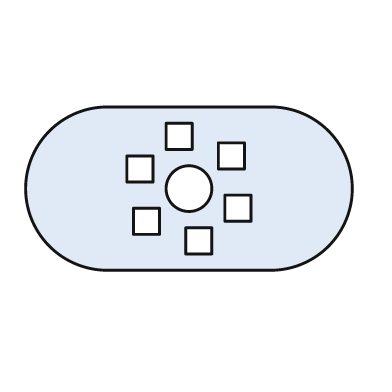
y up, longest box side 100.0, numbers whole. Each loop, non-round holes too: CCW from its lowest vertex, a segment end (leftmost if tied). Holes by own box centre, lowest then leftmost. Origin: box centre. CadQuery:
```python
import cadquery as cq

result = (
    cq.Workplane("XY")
    .moveTo(-25.0, -25.0)
    .lineTo(25.0, -25.0)
    .threePointArc((50.0, 0.0), (25.0, 25.0))
    .lineTo(-25.0, 25.0)
    .threePointArc((-50.0, 0.0), (-25.0, -25.0))
    .close()
    .moveTo(-1.0, -20.0)
    .lineTo(7.0, -20.0)
    .lineTo(7.0, -12.0)
    .lineTo(-1.0, -12.0)
    .close()
    .moveTo(-17.0, -14.0)
    .lineTo(-9.0, -14.0)
    .lineTo(-9.0, -6.0)
    .lineTo(-17.0, -6.0)
    .close()
    .moveTo(11.0, -10.0)
    .lineTo(19.0, -10.0)
    .lineTo(19.0, -2.0)
    .lineTo(11.0, -2.0)
    .close()
    .moveTo(0.0, 0.0)
    .circle(7.0)
    .moveTo(-19.0, 2.0)
    .lineTo(-11.0, 2.0)
    .lineTo(-11.0, 10.0)
    .lineTo(-19.0, 10.0)
    .close()
    .moveTo(9.0, 6.0)
    .lineTo(17.0, 6.0)
    .lineTo(17.0, 14.0)
    .lineTo(9.0, 14.0)
    .close()
    .moveTo(-7.0, 12.0)
    .lineTo(1.0, 12.0)
    .lineTo(1.0, 20.0)
    .lineTo(-7.0, 20.0)
    .close()
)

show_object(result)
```